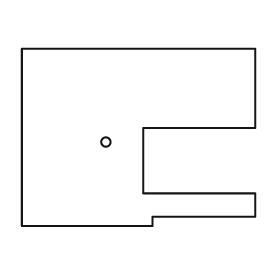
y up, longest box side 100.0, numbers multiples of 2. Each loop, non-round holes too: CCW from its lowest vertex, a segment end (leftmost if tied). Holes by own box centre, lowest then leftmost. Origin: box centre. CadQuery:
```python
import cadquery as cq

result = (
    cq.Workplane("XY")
    .moveTo(-50.0, -38.0)
    .lineTo(6.0, -38.0)
    .lineTo(6.0, -34.0)
    .lineTo(50.0, -34.0)
    .lineTo(50.0, -24.0)
    .lineTo(2.0, -24.0)
    .lineTo(2.0, 4.0)
    .lineTo(50.0, 4.0)
    .lineTo(50.0, 38.0)
    .lineTo(-50.0, 38.0)
    .close()
    .moveTo(-14.0, -2.0)
    .circle(2.0)
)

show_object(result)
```